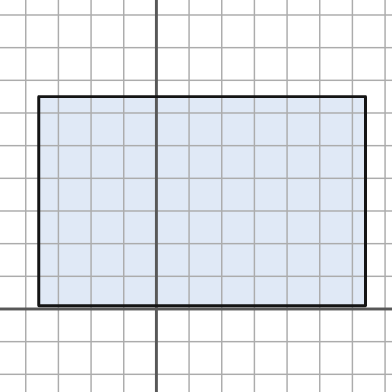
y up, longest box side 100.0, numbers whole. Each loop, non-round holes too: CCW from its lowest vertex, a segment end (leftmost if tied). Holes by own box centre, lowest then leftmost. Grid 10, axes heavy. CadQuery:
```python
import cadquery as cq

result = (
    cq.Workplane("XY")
    .moveTo(-36.0, 1.0)
    .lineTo(64.0, 1.0)
    .lineTo(64.0, 65.0)
    .lineTo(-36.0, 65.0)
    .close()
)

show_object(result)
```